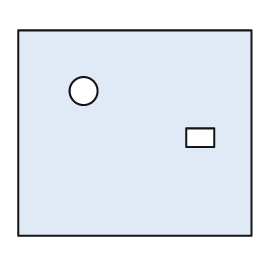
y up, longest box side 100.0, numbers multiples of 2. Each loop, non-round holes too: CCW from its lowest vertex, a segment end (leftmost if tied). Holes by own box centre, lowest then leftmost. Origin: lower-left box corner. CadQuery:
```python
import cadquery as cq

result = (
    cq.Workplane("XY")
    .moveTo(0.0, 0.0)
    .lineTo(100.0, 0.0)
    .lineTo(100.0, 88.0)
    .lineTo(0.0, 88.0)
    .close()
    .moveTo(72.0, 38.0)
    .lineTo(84.0, 38.0)
    .lineTo(84.0, 46.0)
    .lineTo(72.0, 46.0)
    .close()
    .moveTo(28.0, 62.0)
    .circle(6.0)
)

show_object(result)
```